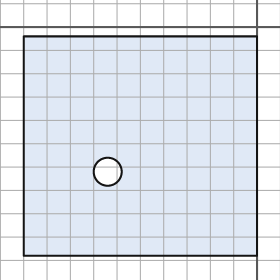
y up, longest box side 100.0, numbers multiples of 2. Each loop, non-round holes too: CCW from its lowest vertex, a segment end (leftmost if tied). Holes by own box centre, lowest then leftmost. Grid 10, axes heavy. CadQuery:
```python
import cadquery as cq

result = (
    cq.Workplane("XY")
    .moveTo(-100.0, -98.0)
    .lineTo(0.0, -98.0)
    .lineTo(0.0, -4.0)
    .lineTo(-100.0, -4.0)
    .close()
    .moveTo(-64.0, -62.0)
    .circle(6.0)
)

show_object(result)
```